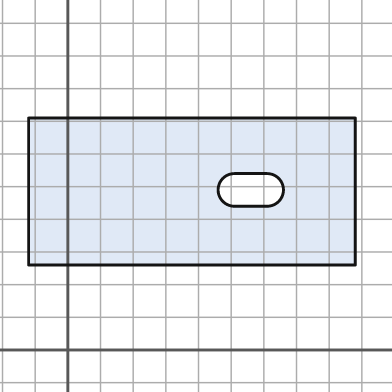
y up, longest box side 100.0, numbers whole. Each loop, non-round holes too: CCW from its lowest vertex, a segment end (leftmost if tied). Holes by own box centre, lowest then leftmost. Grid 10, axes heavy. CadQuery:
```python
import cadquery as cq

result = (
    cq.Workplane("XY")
    .moveTo(-12.0, 26.0)
    .lineTo(88.0, 26.0)
    .lineTo(88.0, 71.0)
    .lineTo(-12.0, 71.0)
    .close()
    .moveTo(51.0, 44.0)
    .lineTo(61.0, 44.0)
    .threePointArc((66.0, 49.0), (61.0, 54.0))
    .lineTo(51.0, 54.0)
    .threePointArc((46.0, 49.0), (51.0, 44.0))
    .close()
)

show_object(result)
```